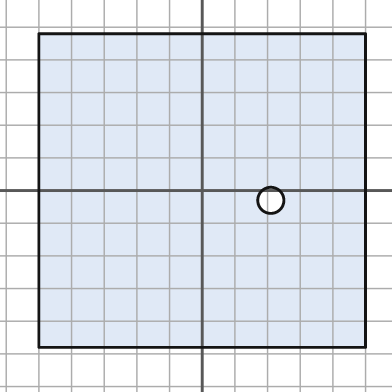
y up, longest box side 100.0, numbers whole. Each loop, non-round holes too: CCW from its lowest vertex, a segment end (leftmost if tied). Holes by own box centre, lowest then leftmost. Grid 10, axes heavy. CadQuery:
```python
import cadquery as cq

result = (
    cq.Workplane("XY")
    .moveTo(-50.0, -48.0)
    .lineTo(50.0, -48.0)
    .lineTo(50.0, 48.0)
    .lineTo(-50.0, 48.0)
    .close()
    .moveTo(21.0, -3.0)
    .circle(4.0)
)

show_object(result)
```